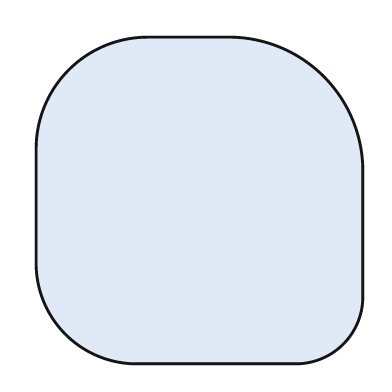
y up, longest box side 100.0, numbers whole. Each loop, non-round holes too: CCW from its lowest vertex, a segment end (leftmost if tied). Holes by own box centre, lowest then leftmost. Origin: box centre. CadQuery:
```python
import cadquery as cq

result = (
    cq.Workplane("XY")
    .moveTo(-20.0, -50.0)
    .lineTo(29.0, -50.0)
    .threePointArc((44.0, -44.0), (50.0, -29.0))
    .lineTo(50.0, 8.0)
    .threePointArc((38.0, 38.0), (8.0, 50.0))
    .lineTo(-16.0, 50.0)
    .threePointArc((-40.0, 40.0), (-50.0, 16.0))
    .lineTo(-50.0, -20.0)
    .threePointArc((-41.0, -41.0), (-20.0, -50.0))
    .close()
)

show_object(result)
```